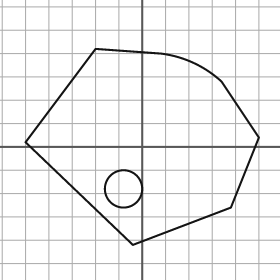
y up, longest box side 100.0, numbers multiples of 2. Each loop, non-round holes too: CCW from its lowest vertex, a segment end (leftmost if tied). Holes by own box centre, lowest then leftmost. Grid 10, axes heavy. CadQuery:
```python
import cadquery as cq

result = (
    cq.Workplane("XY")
    .moveTo(-4.0, -42.0)
    .lineTo(38.0, -26.0)
    .lineTo(50.0, 4.0)
    .lineTo(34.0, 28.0)
    .threePointArc((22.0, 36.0), (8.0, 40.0))
    .lineTo(-20.0, 42.0)
    .lineTo(-50.0, 2.0)
    .close()
    .moveTo(-8.0, -18.0)
    .circle(8.0)
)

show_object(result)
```